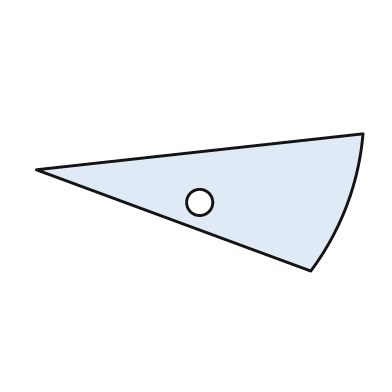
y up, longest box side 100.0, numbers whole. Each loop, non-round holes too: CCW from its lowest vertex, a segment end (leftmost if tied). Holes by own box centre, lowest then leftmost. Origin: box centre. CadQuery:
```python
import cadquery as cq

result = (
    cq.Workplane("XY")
    .moveTo(34.0, -21.0)
    .threePointArc((45.0, -1.0), (50.0, 21.0))
    .lineTo(-50.0, 10.0)
    .close()
    .moveTo(0.0, 0.0)
    .circle(4.0)
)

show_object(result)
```